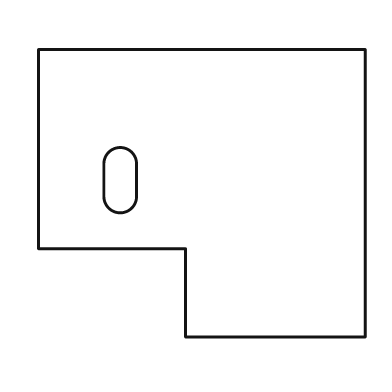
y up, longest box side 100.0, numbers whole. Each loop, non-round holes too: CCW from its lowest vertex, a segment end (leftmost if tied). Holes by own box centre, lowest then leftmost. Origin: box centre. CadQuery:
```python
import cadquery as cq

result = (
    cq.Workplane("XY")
    .moveTo(-5.0, -44.0)
    .lineTo(50.0, -44.0)
    .lineTo(50.0, 44.0)
    .lineTo(-50.0, 44.0)
    .lineTo(-50.0, -17.0)
    .lineTo(-5.0, -17.0)
    .close()
    .moveTo(-30.0, -1.0)
    .threePointArc((-25.0, -6.0), (-20.0, -1.0))
    .lineTo(-20.0, 9.0)
    .threePointArc((-25.0, 14.0), (-30.0, 9.0))
    .close()
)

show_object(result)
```